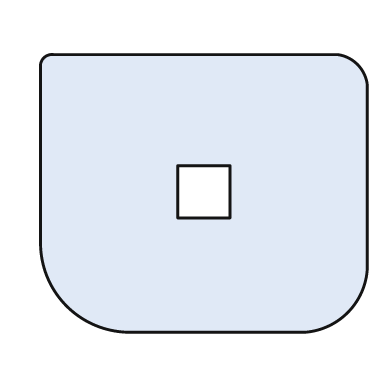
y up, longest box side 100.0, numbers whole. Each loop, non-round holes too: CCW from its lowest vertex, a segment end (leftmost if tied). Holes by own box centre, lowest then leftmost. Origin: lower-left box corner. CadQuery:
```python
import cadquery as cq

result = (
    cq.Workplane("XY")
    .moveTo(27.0, 0.0)
    .lineTo(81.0, 0.0)
    .threePointArc((94.0, 6.0), (100.0, 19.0))
    .lineTo(100.0, 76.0)
    .threePointArc((97.0, 82.0), (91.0, 85.0))
    .lineTo(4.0, 85.0)
    .threePointArc((1.0, 84.0), (0.0, 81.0))
    .lineTo(0.0, 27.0)
    .threePointArc((8.0, 8.0), (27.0, 0.0))
    .close()
    .moveTo(42.0, 35.0)
    .lineTo(58.0, 35.0)
    .lineTo(58.0, 51.0)
    .lineTo(42.0, 51.0)
    .close()
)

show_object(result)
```